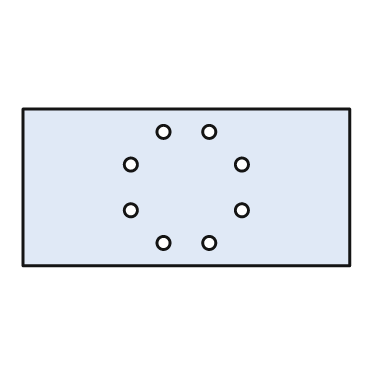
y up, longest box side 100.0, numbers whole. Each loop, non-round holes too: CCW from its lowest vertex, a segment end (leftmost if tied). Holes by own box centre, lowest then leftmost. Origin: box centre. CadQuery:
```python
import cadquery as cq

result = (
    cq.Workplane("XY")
    .moveTo(-50.0, -24.0)
    .lineTo(50.0, -24.0)
    .lineTo(50.0, 24.0)
    .lineTo(-50.0, 24.0)
    .close()
    .moveTo(-7.0, -17.0)
    .circle(2.0)
    .moveTo(7.0, -17.0)
    .circle(2.0)
    .moveTo(-17.0, -7.0)
    .circle(2.0)
    .moveTo(17.0, -7.0)
    .circle(2.0)
    .moveTo(-17.0, 7.0)
    .circle(2.0)
    .moveTo(17.0, 7.0)
    .circle(2.0)
    .moveTo(-7.0, 17.0)
    .circle(2.0)
    .moveTo(7.0, 17.0)
    .circle(2.0)
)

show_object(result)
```